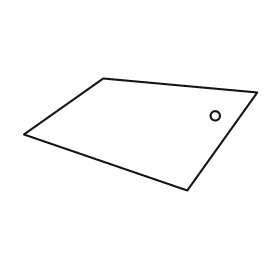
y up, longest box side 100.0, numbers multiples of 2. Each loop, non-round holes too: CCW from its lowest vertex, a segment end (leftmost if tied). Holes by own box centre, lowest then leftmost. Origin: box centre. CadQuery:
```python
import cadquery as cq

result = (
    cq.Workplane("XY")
    .moveTo(20.0, -24.0)
    .lineTo(50.0, 18.0)
    .lineTo(-16.0, 24.0)
    .lineTo(-50.0, 0.0)
    .close()
    .moveTo(32.0, 8.0)
    .circle(2.0)
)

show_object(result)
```